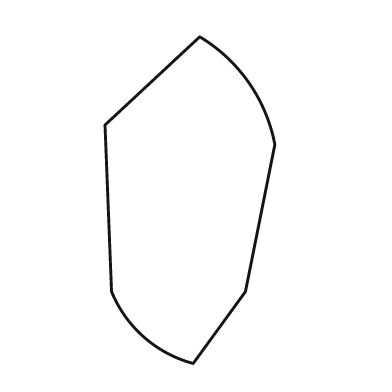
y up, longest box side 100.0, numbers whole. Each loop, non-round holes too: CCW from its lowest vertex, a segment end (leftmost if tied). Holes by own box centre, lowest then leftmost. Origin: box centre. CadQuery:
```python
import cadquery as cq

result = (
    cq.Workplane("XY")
    .moveTo(1.0, -50.0)
    .lineTo(17.0, -28.0)
    .lineTo(26.0, 17.0)
    .threePointArc((18.0, 36.0), (3.0, 50.0))
    .lineTo(-26.0, 23.0)
    .lineTo(-24.0, -28.0)
    .threePointArc((-14.0, -42.0), (1.0, -50.0))
    .close()
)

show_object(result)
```